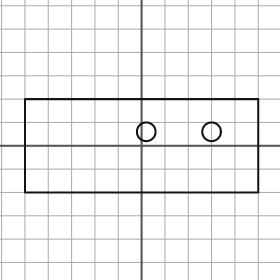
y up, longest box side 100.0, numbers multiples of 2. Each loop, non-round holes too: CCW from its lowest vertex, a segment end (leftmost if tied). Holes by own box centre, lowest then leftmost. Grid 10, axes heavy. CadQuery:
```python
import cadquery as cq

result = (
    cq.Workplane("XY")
    .moveTo(-50.0, -20.0)
    .lineTo(50.0, -20.0)
    .lineTo(50.0, 20.0)
    .lineTo(-50.0, 20.0)
    .close()
    .moveTo(2.0, 6.0)
    .circle(4.0)
    .moveTo(30.0, 6.0)
    .circle(4.0)
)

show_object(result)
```